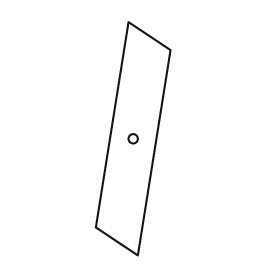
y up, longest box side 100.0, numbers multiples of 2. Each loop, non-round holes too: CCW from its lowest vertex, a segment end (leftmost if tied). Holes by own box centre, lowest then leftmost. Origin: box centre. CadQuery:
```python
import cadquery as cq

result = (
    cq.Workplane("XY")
    .moveTo(2.0, -50.0)
    .lineTo(16.0, 38.0)
    .lineTo(-2.0, 50.0)
    .lineTo(-16.0, -38.0)
    .close()
    .moveTo(0.0, 0.0)
    .circle(2.0)
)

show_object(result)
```